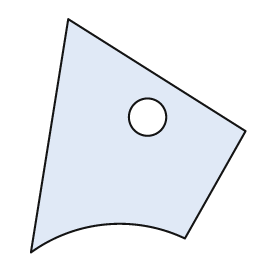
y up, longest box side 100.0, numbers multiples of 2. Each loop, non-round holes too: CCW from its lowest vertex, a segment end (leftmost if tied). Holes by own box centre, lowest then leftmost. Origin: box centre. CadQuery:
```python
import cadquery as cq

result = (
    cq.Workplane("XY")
    .moveTo(-46.0, -50.0)
    .threePointArc((-14.0, -38.0), (20.0, -44.0))
    .lineTo(46.0, 2.0)
    .lineTo(-30.0, 50.0)
    .close()
    .moveTo(4.0, 8.0)
    .circle(8.0)
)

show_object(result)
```